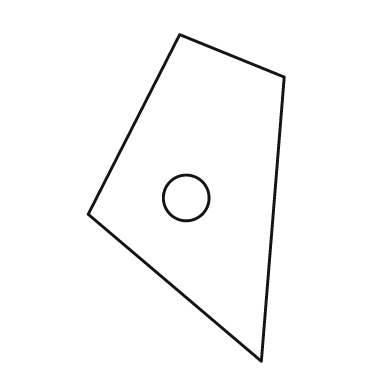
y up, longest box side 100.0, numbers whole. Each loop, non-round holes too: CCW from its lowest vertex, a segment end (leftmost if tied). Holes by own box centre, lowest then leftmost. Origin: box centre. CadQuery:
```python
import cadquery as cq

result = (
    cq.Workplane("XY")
    .moveTo(23.0, -50.0)
    .lineTo(30.0, 37.0)
    .lineTo(-2.0, 50.0)
    .lineTo(-30.0, -5.0)
    .close()
    .moveTo(0.0, 0.0)
    .circle(7.0)
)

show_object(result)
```